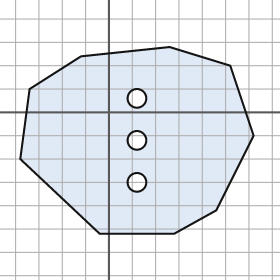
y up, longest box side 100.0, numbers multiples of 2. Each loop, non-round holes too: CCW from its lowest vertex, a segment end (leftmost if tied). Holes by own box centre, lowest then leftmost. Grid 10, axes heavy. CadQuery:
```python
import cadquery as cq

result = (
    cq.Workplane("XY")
    .moveTo(-4.0, -52.0)
    .lineTo(28.0, -52.0)
    .lineTo(46.0, -42.0)
    .lineTo(62.0, -10.0)
    .lineTo(52.0, 20.0)
    .lineTo(26.0, 28.0)
    .lineTo(-12.0, 24.0)
    .lineTo(-34.0, 10.0)
    .lineTo(-38.0, -20.0)
    .close()
    .moveTo(12.0, -30.0)
    .circle(4.0)
    .moveTo(12.0, -12.0)
    .circle(4.0)
    .moveTo(12.0, 6.0)
    .circle(4.0)
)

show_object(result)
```